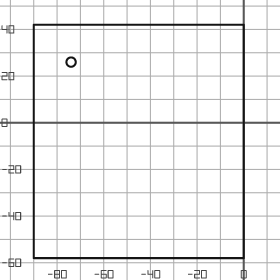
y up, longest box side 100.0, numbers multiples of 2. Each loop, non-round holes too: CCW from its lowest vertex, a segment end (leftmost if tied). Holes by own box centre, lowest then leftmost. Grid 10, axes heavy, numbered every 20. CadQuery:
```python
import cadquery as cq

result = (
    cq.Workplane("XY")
    .moveTo(-90.0, -58.0)
    .lineTo(0.0, -58.0)
    .lineTo(0.0, 42.0)
    .lineTo(-90.0, 42.0)
    .close()
    .moveTo(-74.0, 26.0)
    .circle(2.0)
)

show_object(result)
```